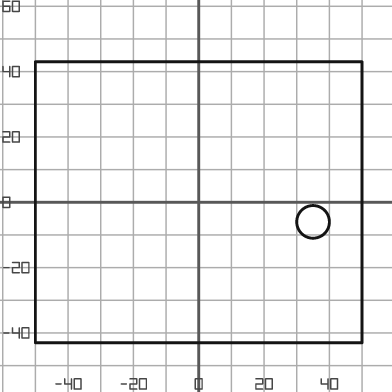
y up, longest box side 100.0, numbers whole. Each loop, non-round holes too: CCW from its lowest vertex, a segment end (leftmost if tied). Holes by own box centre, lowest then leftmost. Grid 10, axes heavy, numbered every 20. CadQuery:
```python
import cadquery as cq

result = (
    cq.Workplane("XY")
    .moveTo(-50.0, -43.0)
    .lineTo(50.0, -43.0)
    .lineTo(50.0, 43.0)
    .lineTo(-50.0, 43.0)
    .close()
    .moveTo(35.0, -6.0)
    .circle(5.0)
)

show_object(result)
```